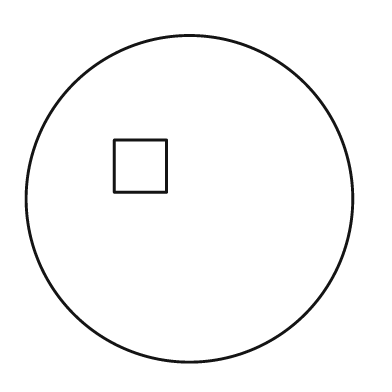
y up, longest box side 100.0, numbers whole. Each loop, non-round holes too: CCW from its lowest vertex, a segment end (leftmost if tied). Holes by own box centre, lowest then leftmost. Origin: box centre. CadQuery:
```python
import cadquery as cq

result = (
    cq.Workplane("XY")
    .moveTo(0.0, 0.0)
    .circle(50.0)
    .moveTo(-23.0, 2.0)
    .lineTo(-7.0, 2.0)
    .lineTo(-7.0, 18.0)
    .lineTo(-23.0, 18.0)
    .close()
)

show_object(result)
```